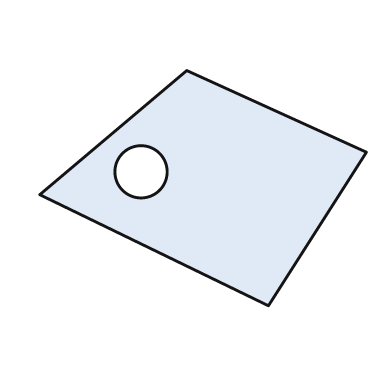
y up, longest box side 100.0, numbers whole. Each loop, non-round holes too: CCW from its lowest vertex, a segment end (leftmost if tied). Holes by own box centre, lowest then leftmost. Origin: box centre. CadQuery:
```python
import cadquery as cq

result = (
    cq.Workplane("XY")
    .moveTo(20.0, -36.0)
    .lineTo(50.0, 11.0)
    .lineTo(-5.0, 36.0)
    .lineTo(-50.0, -2.0)
    .close()
    .moveTo(-19.0, 5.0)
    .circle(8.0)
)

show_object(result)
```